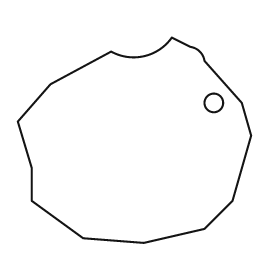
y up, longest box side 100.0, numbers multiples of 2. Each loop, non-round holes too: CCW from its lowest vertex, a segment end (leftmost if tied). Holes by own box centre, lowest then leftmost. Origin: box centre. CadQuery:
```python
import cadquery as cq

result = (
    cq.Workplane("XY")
    .moveTo(4.0, -44.0)
    .lineTo(30.0, -38.0)
    .lineTo(42.0, -26.0)
    .lineTo(50.0, 2.0)
    .lineTo(46.0, 16.0)
    .lineTo(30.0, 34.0)
    .threePointArc((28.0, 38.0), (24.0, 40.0))
    .lineTo(16.0, 44.0)
    .threePointArc((4.0, 36.0), (-10.0, 38.0))
    .lineTo(-36.0, 24.0)
    .lineTo(-50.0, 8.0)
    .lineTo(-44.0, -12.0)
    .lineTo(-44.0, -26.0)
    .lineTo(-22.0, -42.0)
    .close()
    .moveTo(34.0, 16.0)
    .circle(4.0)
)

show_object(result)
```